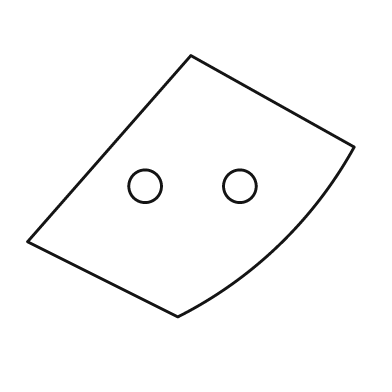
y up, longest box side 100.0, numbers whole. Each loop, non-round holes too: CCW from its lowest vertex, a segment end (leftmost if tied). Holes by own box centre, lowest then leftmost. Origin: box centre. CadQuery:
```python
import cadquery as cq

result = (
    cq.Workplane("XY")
    .moveTo(-4.0, -40.0)
    .threePointArc((27.0, -18.0), (50.0, 12.0))
    .lineTo(0.0, 40.0)
    .lineTo(-50.0, -17.0)
    .close()
    .moveTo(-14.0, 0.0)
    .circle(5.0)
    .moveTo(15.0, 0.0)
    .circle(5.0)
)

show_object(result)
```